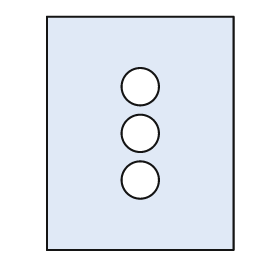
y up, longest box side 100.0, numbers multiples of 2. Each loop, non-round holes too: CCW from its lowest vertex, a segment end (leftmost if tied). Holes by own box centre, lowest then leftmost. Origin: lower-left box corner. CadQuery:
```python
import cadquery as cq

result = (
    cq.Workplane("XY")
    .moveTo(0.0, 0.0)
    .lineTo(80.0, 0.0)
    .lineTo(80.0, 100.0)
    .lineTo(0.0, 100.0)
    .close()
    .moveTo(40.0, 30.0)
    .circle(8.0)
    .moveTo(40.0, 50.0)
    .circle(8.0)
    .moveTo(40.0, 70.0)
    .circle(8.0)
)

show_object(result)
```